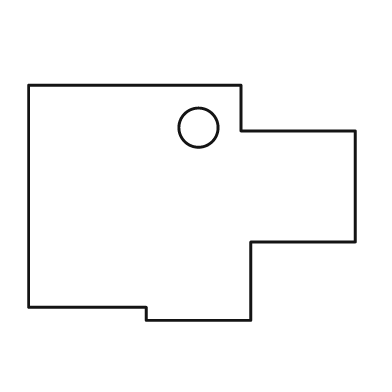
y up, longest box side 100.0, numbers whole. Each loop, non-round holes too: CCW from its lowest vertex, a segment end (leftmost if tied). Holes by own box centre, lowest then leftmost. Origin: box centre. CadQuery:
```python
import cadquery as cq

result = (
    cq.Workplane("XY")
    .moveTo(-14.0, -36.0)
    .lineTo(18.0, -36.0)
    .lineTo(18.0, -12.0)
    .lineTo(50.0, -12.0)
    .lineTo(50.0, 22.0)
    .lineTo(15.0, 22.0)
    .lineTo(15.0, 36.0)
    .lineTo(-50.0, 36.0)
    .lineTo(-50.0, -32.0)
    .lineTo(-14.0, -32.0)
    .close()
    .moveTo(2.0, 23.0)
    .circle(6.0)
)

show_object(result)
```